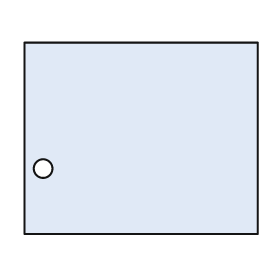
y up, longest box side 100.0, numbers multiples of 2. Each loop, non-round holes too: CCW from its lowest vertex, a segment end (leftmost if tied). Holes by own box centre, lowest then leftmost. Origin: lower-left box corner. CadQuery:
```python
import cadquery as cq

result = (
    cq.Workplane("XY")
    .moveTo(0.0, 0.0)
    .lineTo(100.0, 0.0)
    .lineTo(100.0, 82.0)
    .lineTo(0.0, 82.0)
    .close()
    .moveTo(8.0, 28.0)
    .circle(4.0)
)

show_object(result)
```